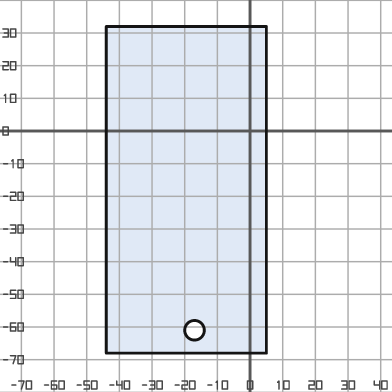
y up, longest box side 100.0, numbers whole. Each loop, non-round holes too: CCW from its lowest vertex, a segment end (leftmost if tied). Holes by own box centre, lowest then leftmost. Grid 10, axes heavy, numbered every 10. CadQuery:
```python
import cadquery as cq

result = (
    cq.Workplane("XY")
    .moveTo(-44.0, -68.0)
    .lineTo(5.0, -68.0)
    .lineTo(5.0, 32.0)
    .lineTo(-44.0, 32.0)
    .close()
    .moveTo(-17.0, -61.0)
    .circle(3.0)
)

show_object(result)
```